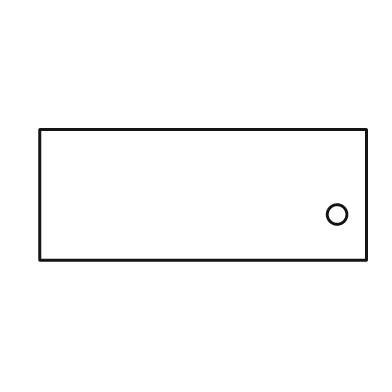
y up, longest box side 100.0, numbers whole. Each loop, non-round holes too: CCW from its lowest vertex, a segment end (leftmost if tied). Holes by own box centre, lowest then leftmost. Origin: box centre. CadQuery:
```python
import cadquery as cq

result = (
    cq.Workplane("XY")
    .moveTo(-50.0, -20.0)
    .lineTo(50.0, -20.0)
    .lineTo(50.0, 20.0)
    .lineTo(-50.0, 20.0)
    .close()
    .moveTo(41.0, -6.0)
    .circle(3.0)
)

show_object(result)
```